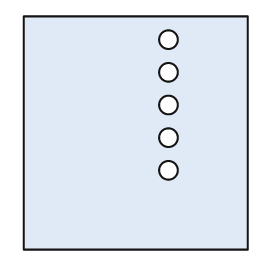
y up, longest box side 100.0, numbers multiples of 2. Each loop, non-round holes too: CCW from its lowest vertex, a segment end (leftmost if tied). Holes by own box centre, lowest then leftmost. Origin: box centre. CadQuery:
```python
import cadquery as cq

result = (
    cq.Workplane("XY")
    .moveTo(-48.0, -50.0)
    .lineTo(48.0, -50.0)
    .lineTo(48.0, 50.0)
    .lineTo(-48.0, 50.0)
    .close()
    .moveTo(14.0, -16.0)
    .circle(4.0)
    .moveTo(14.0, -2.0)
    .circle(4.0)
    .moveTo(14.0, 12.0)
    .circle(4.0)
    .moveTo(14.0, 26.0)
    .circle(4.0)
    .moveTo(14.0, 40.0)
    .circle(4.0)
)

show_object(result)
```